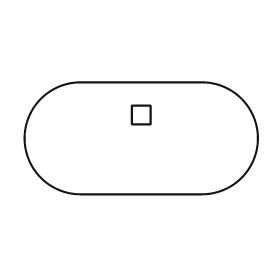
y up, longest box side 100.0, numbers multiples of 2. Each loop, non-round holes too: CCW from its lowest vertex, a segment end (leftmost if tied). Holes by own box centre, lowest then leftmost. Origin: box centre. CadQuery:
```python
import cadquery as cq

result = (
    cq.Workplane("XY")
    .moveTo(-26.0, -24.0)
    .lineTo(26.0, -24.0)
    .threePointArc((50.0, 0.0), (26.0, 24.0))
    .lineTo(-26.0, 24.0)
    .threePointArc((-50.0, 0.0), (-26.0, -24.0))
    .close()
    .moveTo(-4.0, 6.0)
    .lineTo(4.0, 6.0)
    .lineTo(4.0, 14.0)
    .lineTo(-4.0, 14.0)
    .close()
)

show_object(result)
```